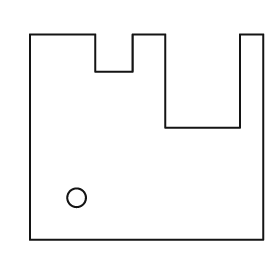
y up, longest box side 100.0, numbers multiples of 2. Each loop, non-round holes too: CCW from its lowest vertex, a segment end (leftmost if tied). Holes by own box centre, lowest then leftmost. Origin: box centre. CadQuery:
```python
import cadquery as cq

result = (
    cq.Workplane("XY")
    .moveTo(-50.0, -44.0)
    .lineTo(50.0, -44.0)
    .lineTo(50.0, 44.0)
    .lineTo(40.0, 44.0)
    .lineTo(40.0, 4.0)
    .lineTo(8.0, 4.0)
    .lineTo(8.0, 44.0)
    .lineTo(-6.0, 44.0)
    .lineTo(-6.0, 28.0)
    .lineTo(-22.0, 28.0)
    .lineTo(-22.0, 44.0)
    .lineTo(-50.0, 44.0)
    .close()
    .moveTo(-30.0, -26.0)
    .circle(4.0)
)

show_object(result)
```